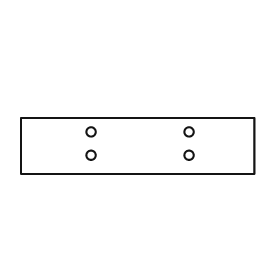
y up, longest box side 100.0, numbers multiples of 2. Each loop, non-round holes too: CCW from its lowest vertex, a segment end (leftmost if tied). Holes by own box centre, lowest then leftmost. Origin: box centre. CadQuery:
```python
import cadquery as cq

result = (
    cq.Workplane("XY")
    .moveTo(-50.0, -12.0)
    .lineTo(50.0, -12.0)
    .lineTo(50.0, 12.0)
    .lineTo(-50.0, 12.0)
    .close()
    .moveTo(-20.0, -4.0)
    .circle(2.0)
    .moveTo(22.0, -4.0)
    .circle(2.0)
    .moveTo(-20.0, 6.0)
    .circle(2.0)
    .moveTo(22.0, 6.0)
    .circle(2.0)
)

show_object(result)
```